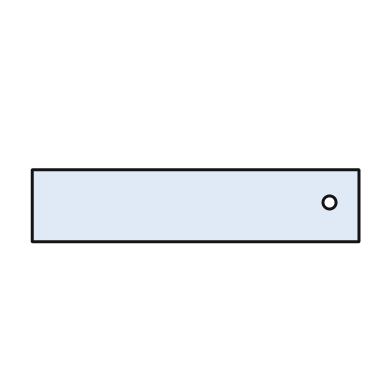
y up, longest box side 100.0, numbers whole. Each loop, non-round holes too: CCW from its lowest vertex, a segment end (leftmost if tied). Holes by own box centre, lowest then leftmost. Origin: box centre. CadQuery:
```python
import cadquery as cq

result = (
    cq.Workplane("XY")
    .moveTo(-50.0, -11.0)
    .lineTo(50.0, -11.0)
    .lineTo(50.0, 11.0)
    .lineTo(-50.0, 11.0)
    .close()
    .moveTo(41.0, 1.0)
    .circle(2.0)
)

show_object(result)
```